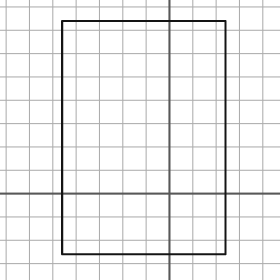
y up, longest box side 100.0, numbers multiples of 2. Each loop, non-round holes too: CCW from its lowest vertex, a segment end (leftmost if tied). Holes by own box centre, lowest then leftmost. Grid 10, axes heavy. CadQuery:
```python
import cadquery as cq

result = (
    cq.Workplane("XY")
    .moveTo(-46.0, -26.0)
    .lineTo(24.0, -26.0)
    .lineTo(24.0, 74.0)
    .lineTo(-46.0, 74.0)
    .close()
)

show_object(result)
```